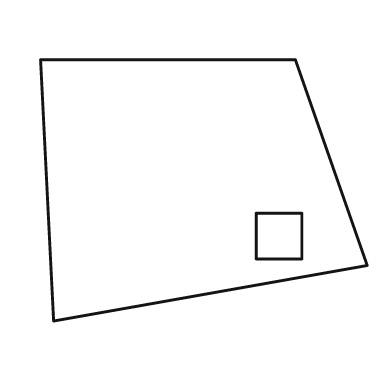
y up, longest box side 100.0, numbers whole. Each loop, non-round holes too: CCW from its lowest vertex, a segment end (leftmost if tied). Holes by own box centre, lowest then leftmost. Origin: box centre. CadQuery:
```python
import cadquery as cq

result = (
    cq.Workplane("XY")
    .moveTo(-46.0, -40.0)
    .lineTo(50.0, -23.0)
    .lineTo(28.0, 40.0)
    .lineTo(-50.0, 40.0)
    .close()
    .moveTo(16.0, -21.0)
    .lineTo(30.0, -21.0)
    .lineTo(30.0, -7.0)
    .lineTo(16.0, -7.0)
    .close()
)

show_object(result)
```